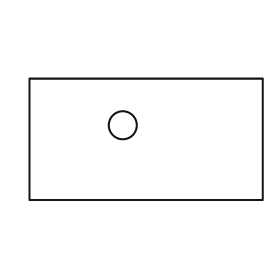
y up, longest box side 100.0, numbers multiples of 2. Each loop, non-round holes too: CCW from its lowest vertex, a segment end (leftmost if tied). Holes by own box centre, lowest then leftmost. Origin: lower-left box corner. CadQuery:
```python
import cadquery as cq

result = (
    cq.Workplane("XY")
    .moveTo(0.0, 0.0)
    .lineTo(100.0, 0.0)
    .lineTo(100.0, 52.0)
    .lineTo(0.0, 52.0)
    .close()
    .moveTo(40.0, 32.0)
    .circle(6.0)
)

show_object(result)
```